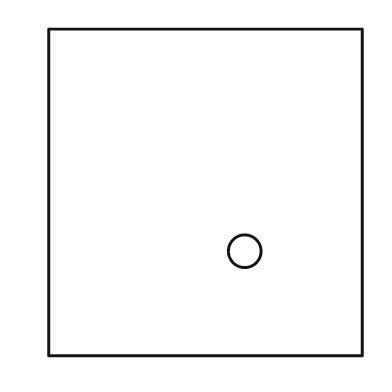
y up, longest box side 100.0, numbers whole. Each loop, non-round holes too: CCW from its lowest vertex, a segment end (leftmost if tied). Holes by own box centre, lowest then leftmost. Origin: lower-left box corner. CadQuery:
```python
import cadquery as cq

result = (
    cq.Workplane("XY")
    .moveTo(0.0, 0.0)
    .lineTo(96.0, 0.0)
    .lineTo(96.0, 100.0)
    .lineTo(0.0, 100.0)
    .close()
    .moveTo(60.0, 32.0)
    .circle(5.0)
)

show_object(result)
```